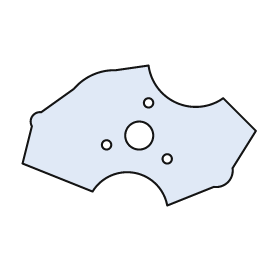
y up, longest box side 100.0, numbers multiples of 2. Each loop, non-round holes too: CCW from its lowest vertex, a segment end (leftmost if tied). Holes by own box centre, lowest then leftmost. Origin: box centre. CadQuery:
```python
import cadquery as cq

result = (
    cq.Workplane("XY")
    .moveTo(12.0, -30.0)
    .lineTo(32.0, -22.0)
    .threePointArc((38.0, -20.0), (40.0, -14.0))
    .lineTo(50.0, 2.0)
    .lineTo(36.0, 16.0)
    .threePointArc((16.0, 14.0), (4.0, 30.0))
    .lineTo(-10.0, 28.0)
    .threePointArc((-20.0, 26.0), (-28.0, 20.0))
    .lineTo(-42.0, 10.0)
    .threePointArc((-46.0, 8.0), (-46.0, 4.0))
    .lineTo(-50.0, -12.0)
    .lineTo(-20.0, -24.0)
    .threePointArc((-2.0, -16.0), (12.0, -30.0))
    .close()
    .moveTo(12.0, -10.0)
    .circle(2.0)
    .moveTo(-14.0, -4.0)
    .circle(2.0)
    .moveTo(0.0, 0.0)
    .circle(6.0)
    .moveTo(4.0, 14.0)
    .circle(2.0)
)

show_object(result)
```